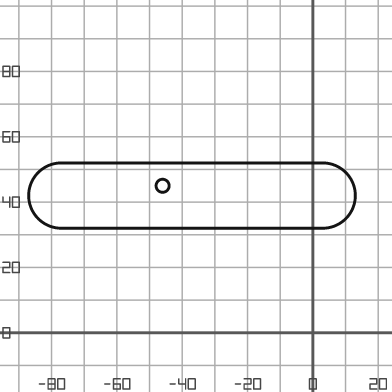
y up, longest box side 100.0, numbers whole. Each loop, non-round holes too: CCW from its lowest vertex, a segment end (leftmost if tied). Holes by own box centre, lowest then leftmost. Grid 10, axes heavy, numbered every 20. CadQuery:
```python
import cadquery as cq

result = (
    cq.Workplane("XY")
    .moveTo(-77.0, 32.0)
    .lineTo(3.0, 32.0)
    .threePointArc((13.0, 42.0), (3.0, 52.0))
    .lineTo(-77.0, 52.0)
    .threePointArc((-87.0, 42.0), (-77.0, 32.0))
    .close()
    .moveTo(-46.0, 45.0)
    .circle(2.0)
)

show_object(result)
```